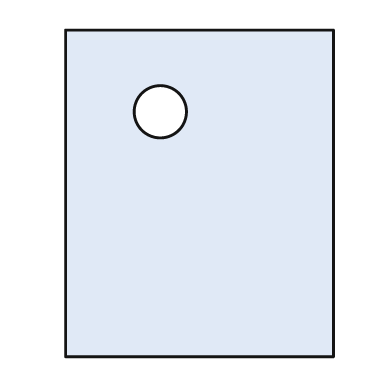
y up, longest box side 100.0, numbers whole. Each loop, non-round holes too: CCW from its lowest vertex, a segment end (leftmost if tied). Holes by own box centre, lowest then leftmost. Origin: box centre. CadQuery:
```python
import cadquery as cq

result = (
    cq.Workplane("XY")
    .moveTo(-41.0, -50.0)
    .lineTo(41.0, -50.0)
    .lineTo(41.0, 50.0)
    .lineTo(-41.0, 50.0)
    .close()
    .moveTo(-12.0, 25.0)
    .circle(8.0)
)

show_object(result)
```